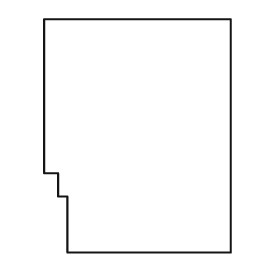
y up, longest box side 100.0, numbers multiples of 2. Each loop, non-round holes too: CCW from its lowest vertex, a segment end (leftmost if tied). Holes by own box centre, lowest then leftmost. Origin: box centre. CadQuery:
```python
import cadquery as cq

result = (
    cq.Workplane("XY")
    .moveTo(-30.0, -50.0)
    .lineTo(40.0, -50.0)
    .lineTo(40.0, 50.0)
    .lineTo(-40.0, 50.0)
    .lineTo(-40.0, -16.0)
    .lineTo(-34.0, -16.0)
    .lineTo(-34.0, -26.0)
    .lineTo(-30.0, -26.0)
    .close()
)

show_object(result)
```